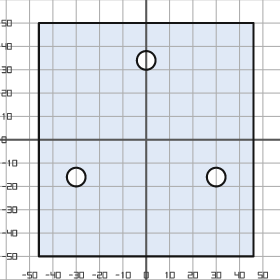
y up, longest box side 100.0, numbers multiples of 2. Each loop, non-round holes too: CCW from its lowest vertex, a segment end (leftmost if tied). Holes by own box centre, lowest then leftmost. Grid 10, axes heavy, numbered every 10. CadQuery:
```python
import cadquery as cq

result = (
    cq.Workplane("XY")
    .moveTo(-46.0, -50.0)
    .lineTo(46.0, -50.0)
    .lineTo(46.0, 50.0)
    .lineTo(-46.0, 50.0)
    .close()
    .moveTo(-30.0, -16.0)
    .circle(4.0)
    .moveTo(30.0, -16.0)
    .circle(4.0)
    .moveTo(0.0, 34.0)
    .circle(4.0)
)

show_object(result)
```